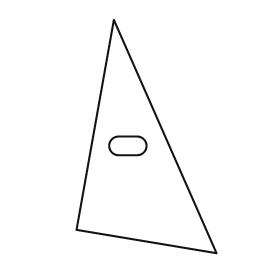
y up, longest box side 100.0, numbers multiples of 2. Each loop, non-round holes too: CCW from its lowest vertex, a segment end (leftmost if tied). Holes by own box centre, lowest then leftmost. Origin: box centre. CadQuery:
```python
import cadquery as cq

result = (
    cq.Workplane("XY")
    .moveTo(30.0, -50.0)
    .lineTo(-14.0, 50.0)
    .lineTo(-30.0, -40.0)
    .close()
    .moveTo(-12.0, -8.0)
    .lineTo(-4.0, -8.0)
    .threePointArc((0.0, -4.0), (-4.0, 0.0))
    .lineTo(-12.0, 0.0)
    .threePointArc((-16.0, -4.0), (-12.0, -8.0))
    .close()
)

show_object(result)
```